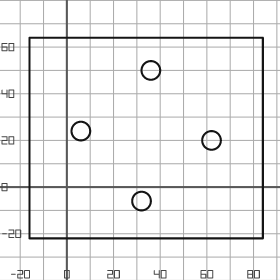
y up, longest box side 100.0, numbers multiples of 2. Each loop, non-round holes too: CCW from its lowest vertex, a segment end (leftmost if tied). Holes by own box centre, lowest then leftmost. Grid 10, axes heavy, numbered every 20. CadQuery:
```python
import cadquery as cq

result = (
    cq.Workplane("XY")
    .moveTo(-16.0, -22.0)
    .lineTo(84.0, -22.0)
    .lineTo(84.0, 64.0)
    .lineTo(-16.0, 64.0)
    .close()
    .moveTo(32.0, -6.0)
    .circle(4.0)
    .moveTo(62.0, 20.0)
    .circle(4.0)
    .moveTo(6.0, 24.0)
    .circle(4.0)
    .moveTo(36.0, 50.0)
    .circle(4.0)
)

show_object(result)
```